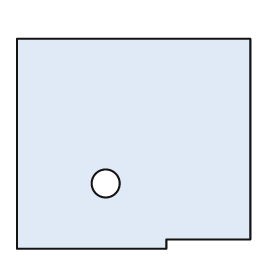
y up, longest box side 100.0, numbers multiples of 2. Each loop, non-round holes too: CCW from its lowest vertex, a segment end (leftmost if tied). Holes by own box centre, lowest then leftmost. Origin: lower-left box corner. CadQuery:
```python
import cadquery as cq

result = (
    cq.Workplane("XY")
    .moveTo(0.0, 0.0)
    .lineTo(64.0, 0.0)
    .lineTo(64.0, 4.0)
    .lineTo(100.0, 4.0)
    .lineTo(100.0, 90.0)
    .lineTo(0.0, 90.0)
    .close()
    .moveTo(38.0, 28.0)
    .circle(6.0)
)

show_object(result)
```